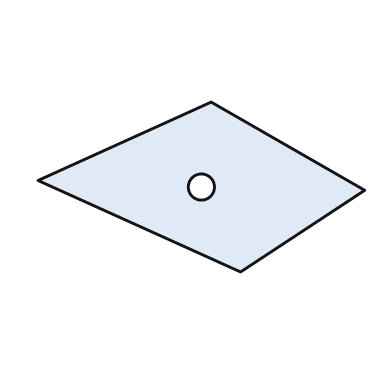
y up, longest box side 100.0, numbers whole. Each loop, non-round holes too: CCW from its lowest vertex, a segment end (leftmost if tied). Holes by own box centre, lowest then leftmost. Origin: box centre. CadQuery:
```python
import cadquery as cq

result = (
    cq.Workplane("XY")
    .moveTo(12.0, -26.0)
    .lineTo(50.0, -1.0)
    .lineTo(3.0, 26.0)
    .lineTo(-50.0, 2.0)
    .close()
    .moveTo(0.0, 0.0)
    .circle(4.0)
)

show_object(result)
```